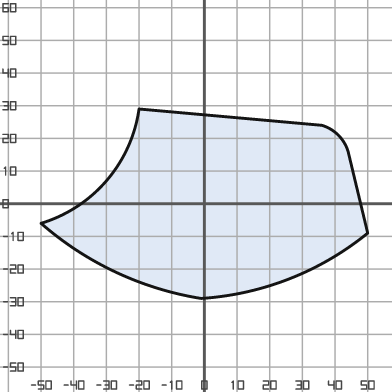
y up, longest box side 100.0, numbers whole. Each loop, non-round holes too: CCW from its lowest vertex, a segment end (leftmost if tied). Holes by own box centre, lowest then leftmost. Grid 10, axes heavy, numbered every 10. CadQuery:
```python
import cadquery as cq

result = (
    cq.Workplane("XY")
    .moveTo(-1.0, -29.0)
    .threePointArc((26.0, -23.0), (50.0, -9.0))
    .lineTo(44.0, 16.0)
    .threePointArc((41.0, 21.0), (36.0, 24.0))
    .lineTo(-20.0, 29.0)
    .threePointArc((-30.0, 7.0), (-50.0, -6.0))
    .threePointArc((-27.0, -21.0), (-1.0, -29.0))
    .close()
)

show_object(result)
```